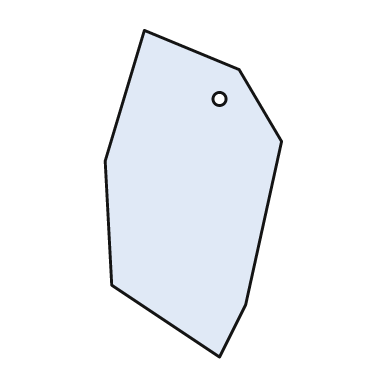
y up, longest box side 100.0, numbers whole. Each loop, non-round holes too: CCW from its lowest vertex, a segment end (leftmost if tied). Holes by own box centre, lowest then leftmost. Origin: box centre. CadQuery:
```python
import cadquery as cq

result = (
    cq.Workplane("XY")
    .moveTo(8.0, -50.0)
    .lineTo(16.0, -34.0)
    .lineTo(27.0, 16.0)
    .lineTo(14.0, 38.0)
    .lineTo(-15.0, 50.0)
    .lineTo(-27.0, 10.0)
    .lineTo(-25.0, -28.0)
    .close()
    .moveTo(8.0, 29.0)
    .circle(2.0)
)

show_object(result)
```